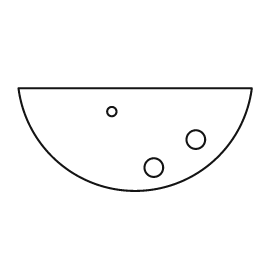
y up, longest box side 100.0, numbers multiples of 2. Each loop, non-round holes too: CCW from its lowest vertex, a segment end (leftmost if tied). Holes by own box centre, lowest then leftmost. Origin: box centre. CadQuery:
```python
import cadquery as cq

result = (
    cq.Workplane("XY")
    .moveTo(-50.0, 22.0)
    .threePointArc((0.0, -22.0), (50.0, 22.0))
    .close()
    .moveTo(8.0, -12.0)
    .circle(4.0)
    .moveTo(26.0, 0.0)
    .circle(4.0)
    .moveTo(-10.0, 12.0)
    .circle(2.0)
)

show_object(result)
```